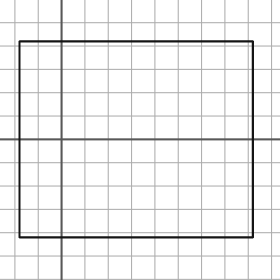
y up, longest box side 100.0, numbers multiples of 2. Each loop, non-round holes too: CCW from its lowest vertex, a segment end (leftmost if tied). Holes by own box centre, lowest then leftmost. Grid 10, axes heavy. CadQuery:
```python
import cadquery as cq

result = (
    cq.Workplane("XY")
    .moveTo(-18.0, -42.0)
    .lineTo(82.0, -42.0)
    .lineTo(82.0, 42.0)
    .lineTo(-18.0, 42.0)
    .close()
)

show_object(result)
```